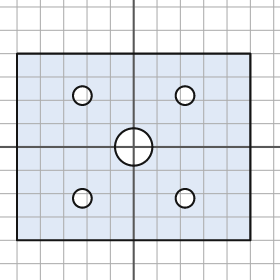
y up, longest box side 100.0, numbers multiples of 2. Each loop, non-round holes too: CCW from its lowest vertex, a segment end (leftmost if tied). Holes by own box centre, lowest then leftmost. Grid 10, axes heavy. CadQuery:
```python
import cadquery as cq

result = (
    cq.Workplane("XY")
    .moveTo(-50.0, -40.0)
    .lineTo(50.0, -40.0)
    .lineTo(50.0, 40.0)
    .lineTo(-50.0, 40.0)
    .close()
    .moveTo(-22.0, -22.0)
    .circle(4.0)
    .moveTo(22.0, -22.0)
    .circle(4.0)
    .moveTo(0.0, 0.0)
    .circle(8.0)
    .moveTo(-22.0, 22.0)
    .circle(4.0)
    .moveTo(22.0, 22.0)
    .circle(4.0)
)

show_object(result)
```